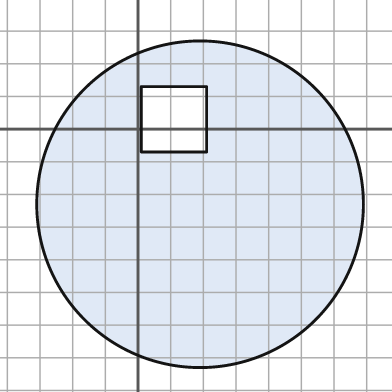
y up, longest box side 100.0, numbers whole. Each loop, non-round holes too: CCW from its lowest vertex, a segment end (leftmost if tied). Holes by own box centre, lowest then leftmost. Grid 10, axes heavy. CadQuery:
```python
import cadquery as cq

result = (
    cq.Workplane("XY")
    .moveTo(19.0, -23.0)
    .circle(50.0)
    .moveTo(1.0, -7.0)
    .lineTo(21.0, -7.0)
    .lineTo(21.0, 13.0)
    .lineTo(1.0, 13.0)
    .close()
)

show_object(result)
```